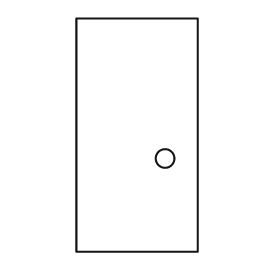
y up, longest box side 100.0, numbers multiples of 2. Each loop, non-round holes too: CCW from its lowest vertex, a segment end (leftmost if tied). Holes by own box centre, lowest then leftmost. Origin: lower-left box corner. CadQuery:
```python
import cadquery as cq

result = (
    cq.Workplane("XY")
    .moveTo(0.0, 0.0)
    .lineTo(52.0, 0.0)
    .lineTo(52.0, 100.0)
    .lineTo(0.0, 100.0)
    .close()
    .moveTo(38.0, 40.0)
    .circle(4.0)
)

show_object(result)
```